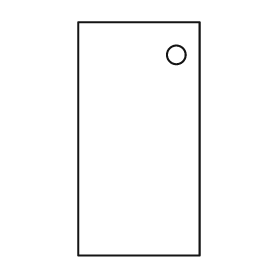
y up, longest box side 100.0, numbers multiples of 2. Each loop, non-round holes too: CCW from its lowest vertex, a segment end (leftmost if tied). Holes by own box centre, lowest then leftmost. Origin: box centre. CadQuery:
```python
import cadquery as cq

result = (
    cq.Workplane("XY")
    .moveTo(-26.0, -50.0)
    .lineTo(26.0, -50.0)
    .lineTo(26.0, 50.0)
    .lineTo(-26.0, 50.0)
    .close()
    .moveTo(16.0, 36.0)
    .circle(4.0)
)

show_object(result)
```